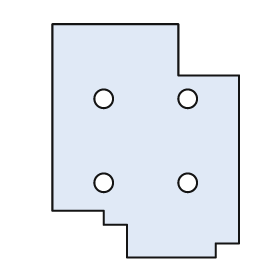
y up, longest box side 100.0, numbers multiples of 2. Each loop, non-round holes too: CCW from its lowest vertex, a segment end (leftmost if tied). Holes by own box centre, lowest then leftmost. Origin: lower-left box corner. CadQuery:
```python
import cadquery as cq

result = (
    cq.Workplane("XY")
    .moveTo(32.0, 0.0)
    .lineTo(70.0, 0.0)
    .lineTo(70.0, 6.0)
    .lineTo(80.0, 6.0)
    .lineTo(80.0, 78.0)
    .lineTo(54.0, 78.0)
    .lineTo(54.0, 100.0)
    .lineTo(0.0, 100.0)
    .lineTo(0.0, 20.0)
    .lineTo(22.0, 20.0)
    .lineTo(22.0, 14.0)
    .lineTo(32.0, 14.0)
    .close()
    .moveTo(22.0, 32.0)
    .circle(4.0)
    .moveTo(58.0, 32.0)
    .circle(4.0)
    .moveTo(22.0, 68.0)
    .circle(4.0)
    .moveTo(58.0, 68.0)
    .circle(4.0)
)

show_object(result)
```